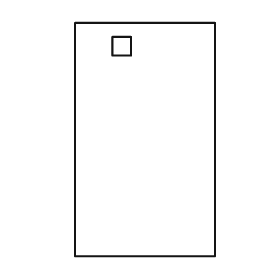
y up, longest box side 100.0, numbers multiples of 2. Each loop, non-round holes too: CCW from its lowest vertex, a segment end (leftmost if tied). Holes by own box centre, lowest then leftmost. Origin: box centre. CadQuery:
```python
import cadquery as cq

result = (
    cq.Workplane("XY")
    .moveTo(-30.0, -50.0)
    .lineTo(30.0, -50.0)
    .lineTo(30.0, 50.0)
    .lineTo(-30.0, 50.0)
    .close()
    .moveTo(-14.0, 36.0)
    .lineTo(-6.0, 36.0)
    .lineTo(-6.0, 44.0)
    .lineTo(-14.0, 44.0)
    .close()
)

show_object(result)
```